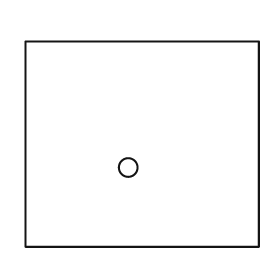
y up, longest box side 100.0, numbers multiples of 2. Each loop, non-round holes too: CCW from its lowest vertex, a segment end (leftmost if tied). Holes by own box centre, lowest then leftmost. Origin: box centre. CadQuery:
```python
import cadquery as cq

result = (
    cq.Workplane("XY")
    .moveTo(-50.0, -44.0)
    .lineTo(50.0, -44.0)
    .lineTo(50.0, 44.0)
    .lineTo(-50.0, 44.0)
    .close()
    .moveTo(-6.0, -10.0)
    .circle(4.0)
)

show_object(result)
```